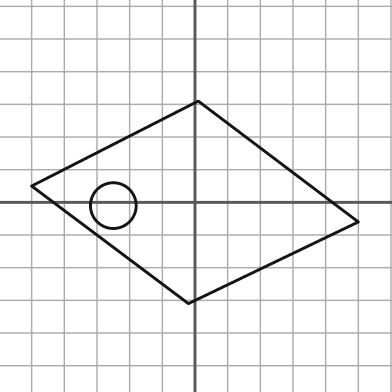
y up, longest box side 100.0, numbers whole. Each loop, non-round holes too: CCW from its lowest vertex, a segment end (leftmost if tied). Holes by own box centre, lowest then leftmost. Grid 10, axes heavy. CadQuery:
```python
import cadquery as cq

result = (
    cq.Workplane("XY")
    .moveTo(-2.0, -31.0)
    .lineTo(50.0, -6.0)
    .lineTo(1.0, 31.0)
    .lineTo(-50.0, 5.0)
    .close()
    .moveTo(-25.0, -1.0)
    .circle(7.0)
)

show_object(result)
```